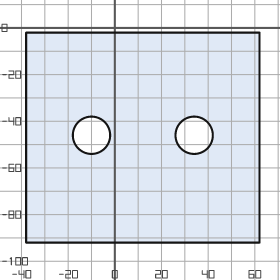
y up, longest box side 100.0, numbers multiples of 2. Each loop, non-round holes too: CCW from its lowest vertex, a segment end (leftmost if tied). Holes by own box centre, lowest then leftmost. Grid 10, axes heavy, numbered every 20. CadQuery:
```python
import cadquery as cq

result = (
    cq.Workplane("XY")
    .moveTo(-38.0, -92.0)
    .lineTo(62.0, -92.0)
    .lineTo(62.0, -2.0)
    .lineTo(-38.0, -2.0)
    .close()
    .moveTo(-10.0, -46.0)
    .circle(8.0)
    .moveTo(34.0, -46.0)
    .circle(8.0)
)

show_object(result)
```